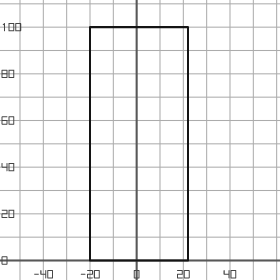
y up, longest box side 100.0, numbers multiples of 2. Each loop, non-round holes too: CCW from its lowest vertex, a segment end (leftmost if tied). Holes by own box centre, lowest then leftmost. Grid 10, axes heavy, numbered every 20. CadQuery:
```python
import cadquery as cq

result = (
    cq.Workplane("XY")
    .moveTo(-20.0, 0.0)
    .lineTo(22.0, 0.0)
    .lineTo(22.0, 100.0)
    .lineTo(-20.0, 100.0)
    .close()
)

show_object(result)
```